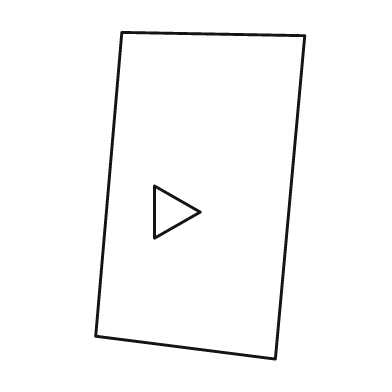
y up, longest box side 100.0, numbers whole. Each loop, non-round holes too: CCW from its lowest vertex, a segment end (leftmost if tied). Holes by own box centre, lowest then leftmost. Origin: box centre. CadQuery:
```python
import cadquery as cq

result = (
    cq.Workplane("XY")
    .moveTo(23.0, -50.0)
    .lineTo(32.0, 49.0)
    .lineTo(-24.0, 50.0)
    .lineTo(-32.0, -43.0)
    .close()
    .moveTo(-14.0, -13.0)
    .lineTo(0.0, -5.0)
    .lineTo(-14.0, 3.0)
    .close()
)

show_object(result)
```